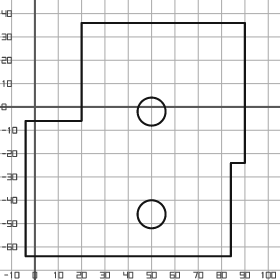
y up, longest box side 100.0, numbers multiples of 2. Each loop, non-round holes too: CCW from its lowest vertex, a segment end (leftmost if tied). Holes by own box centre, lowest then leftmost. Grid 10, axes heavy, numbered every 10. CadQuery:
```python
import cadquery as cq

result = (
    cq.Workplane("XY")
    .moveTo(-4.0, -64.0)
    .lineTo(84.0, -64.0)
    .lineTo(84.0, -24.0)
    .lineTo(90.0, -24.0)
    .lineTo(90.0, 36.0)
    .lineTo(20.0, 36.0)
    .lineTo(20.0, -6.0)
    .lineTo(-4.0, -6.0)
    .close()
    .moveTo(50.0, -46.0)
    .circle(6.0)
    .moveTo(50.0, -2.0)
    .circle(6.0)
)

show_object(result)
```